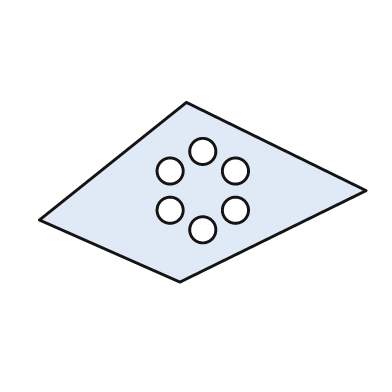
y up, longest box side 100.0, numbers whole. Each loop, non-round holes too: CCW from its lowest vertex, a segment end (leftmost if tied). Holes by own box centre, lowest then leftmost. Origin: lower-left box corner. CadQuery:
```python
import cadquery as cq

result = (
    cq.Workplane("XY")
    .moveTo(43.0, 0.0)
    .lineTo(100.0, 28.0)
    .lineTo(45.0, 55.0)
    .lineTo(0.0, 19.0)
    .close()
    .moveTo(50.0, 16.0)
    .circle(4.0)
    .moveTo(40.0, 22.0)
    .circle(4.0)
    .moveTo(60.0, 22.0)
    .circle(4.0)
    .moveTo(40.0, 34.0)
    .circle(4.0)
    .moveTo(60.0, 34.0)
    .circle(4.0)
    .moveTo(50.0, 40.0)
    .circle(4.0)
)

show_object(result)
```